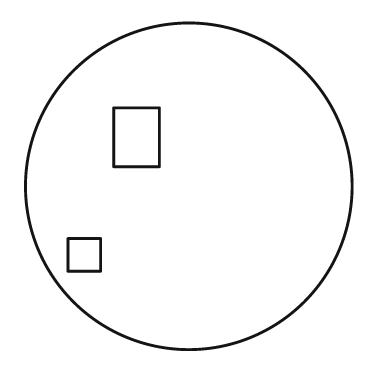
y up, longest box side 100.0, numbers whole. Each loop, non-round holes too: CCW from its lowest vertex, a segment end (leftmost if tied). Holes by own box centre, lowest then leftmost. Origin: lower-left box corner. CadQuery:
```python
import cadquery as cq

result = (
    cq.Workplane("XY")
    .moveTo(50.0, 50.0)
    .circle(50.0)
    .moveTo(13.0, 24.0)
    .lineTo(23.0, 24.0)
    .lineTo(23.0, 34.0)
    .lineTo(13.0, 34.0)
    .close()
    .moveTo(27.0, 56.0)
    .lineTo(41.0, 56.0)
    .lineTo(41.0, 74.0)
    .lineTo(27.0, 74.0)
    .close()
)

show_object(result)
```